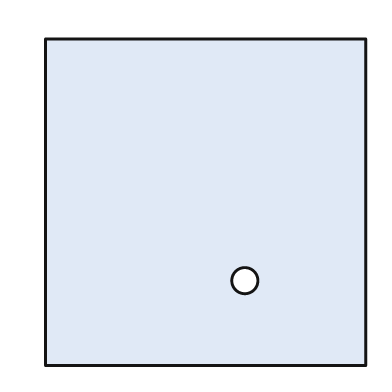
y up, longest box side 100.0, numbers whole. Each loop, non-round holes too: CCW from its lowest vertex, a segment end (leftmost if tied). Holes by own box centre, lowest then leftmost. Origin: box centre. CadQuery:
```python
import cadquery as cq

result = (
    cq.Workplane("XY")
    .moveTo(-49.0, -50.0)
    .lineTo(49.0, -50.0)
    .lineTo(49.0, 50.0)
    .lineTo(-49.0, 50.0)
    .close()
    .moveTo(12.0, -24.0)
    .circle(4.0)
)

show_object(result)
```